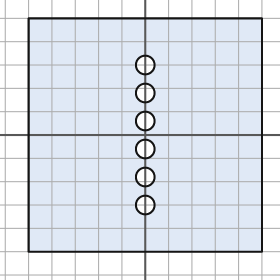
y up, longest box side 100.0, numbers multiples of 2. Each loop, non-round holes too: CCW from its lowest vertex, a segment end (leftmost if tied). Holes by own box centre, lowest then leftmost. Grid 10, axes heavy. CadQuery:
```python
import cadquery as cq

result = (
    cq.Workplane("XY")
    .moveTo(-50.0, -50.0)
    .lineTo(50.0, -50.0)
    .lineTo(50.0, 50.0)
    .lineTo(-50.0, 50.0)
    .close()
    .moveTo(0.0, -30.0)
    .circle(4.0)
    .moveTo(0.0, -18.0)
    .circle(4.0)
    .moveTo(0.0, -6.0)
    .circle(4.0)
    .moveTo(0.0, 6.0)
    .circle(4.0)
    .moveTo(0.0, 18.0)
    .circle(4.0)
    .moveTo(0.0, 30.0)
    .circle(4.0)
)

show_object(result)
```